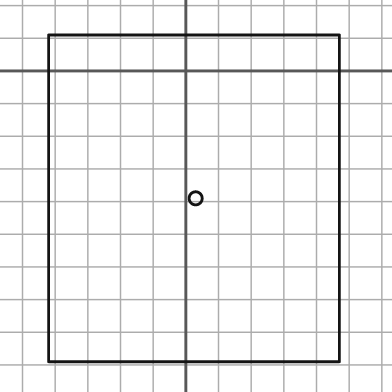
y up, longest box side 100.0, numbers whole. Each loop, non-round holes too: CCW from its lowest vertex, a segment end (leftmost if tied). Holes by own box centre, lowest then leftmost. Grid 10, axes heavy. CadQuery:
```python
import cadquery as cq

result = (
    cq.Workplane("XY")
    .moveTo(-42.0, -89.0)
    .lineTo(47.0, -89.0)
    .lineTo(47.0, 11.0)
    .lineTo(-42.0, 11.0)
    .close()
    .moveTo(3.0, -39.0)
    .circle(2.0)
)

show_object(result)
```